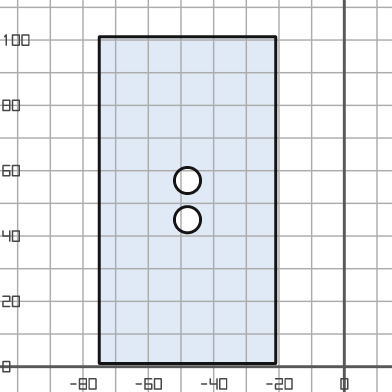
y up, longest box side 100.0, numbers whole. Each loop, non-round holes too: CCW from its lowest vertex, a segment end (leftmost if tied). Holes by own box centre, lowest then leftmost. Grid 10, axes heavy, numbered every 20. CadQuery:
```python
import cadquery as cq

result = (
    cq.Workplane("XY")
    .moveTo(-75.0, 1.0)
    .lineTo(-21.0, 1.0)
    .lineTo(-21.0, 101.0)
    .lineTo(-75.0, 101.0)
    .close()
    .moveTo(-48.0, 45.0)
    .circle(4.0)
    .moveTo(-48.0, 57.0)
    .circle(4.0)
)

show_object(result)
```